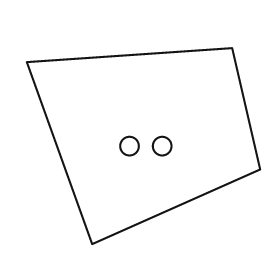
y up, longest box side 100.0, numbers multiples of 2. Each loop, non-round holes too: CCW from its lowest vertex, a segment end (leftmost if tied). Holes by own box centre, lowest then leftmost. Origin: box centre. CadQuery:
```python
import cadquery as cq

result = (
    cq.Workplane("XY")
    .moveTo(-22.0, -42.0)
    .lineTo(50.0, -10.0)
    .lineTo(38.0, 42.0)
    .lineTo(-50.0, 36.0)
    .close()
    .moveTo(-6.0, 0.0)
    .circle(4.0)
    .moveTo(8.0, 0.0)
    .circle(4.0)
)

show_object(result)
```